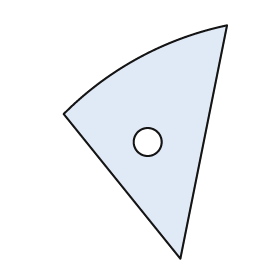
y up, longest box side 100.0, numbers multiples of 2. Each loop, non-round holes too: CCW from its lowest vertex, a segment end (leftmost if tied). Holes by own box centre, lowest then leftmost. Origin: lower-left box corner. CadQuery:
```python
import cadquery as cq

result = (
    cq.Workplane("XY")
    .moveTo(50.0, 0.0)
    .lineTo(70.0, 100.0)
    .threePointArc((32.0, 86.0), (0.0, 62.0))
    .close()
    .moveTo(36.0, 50.0)
    .circle(6.0)
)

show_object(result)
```